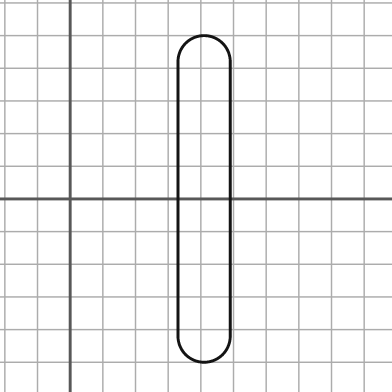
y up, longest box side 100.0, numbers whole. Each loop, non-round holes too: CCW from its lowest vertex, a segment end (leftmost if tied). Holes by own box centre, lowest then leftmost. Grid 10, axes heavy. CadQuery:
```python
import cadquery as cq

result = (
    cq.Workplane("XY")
    .moveTo(33.0, -42.0)
    .threePointArc((41.0, -50.0), (49.0, -42.0))
    .lineTo(49.0, 42.0)
    .threePointArc((41.0, 50.0), (33.0, 42.0))
    .close()
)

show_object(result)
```